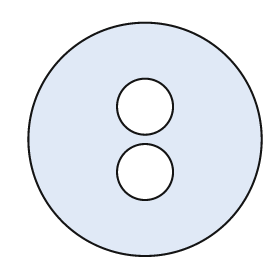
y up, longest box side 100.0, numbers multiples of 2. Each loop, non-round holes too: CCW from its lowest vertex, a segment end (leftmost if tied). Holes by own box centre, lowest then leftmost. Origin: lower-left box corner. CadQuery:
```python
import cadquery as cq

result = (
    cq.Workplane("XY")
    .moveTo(50.0, 50.0)
    .circle(50.0)
    .moveTo(50.0, 36.0)
    .circle(12.0)
    .moveTo(50.0, 64.0)
    .circle(12.0)
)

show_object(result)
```